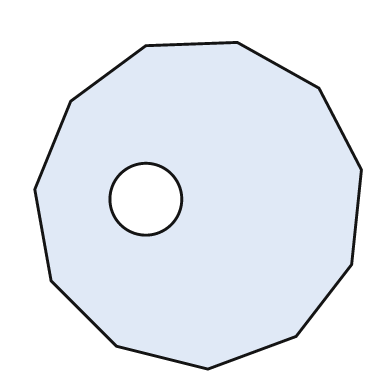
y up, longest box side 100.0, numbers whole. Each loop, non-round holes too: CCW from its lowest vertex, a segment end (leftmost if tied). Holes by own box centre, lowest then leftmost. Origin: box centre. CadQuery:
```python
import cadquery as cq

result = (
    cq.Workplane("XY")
    .moveTo(3.0, -50.0)
    .lineTo(30.0, -40.0)
    .lineTo(47.0, -18.0)
    .lineTo(50.0, 11.0)
    .lineTo(37.0, 36.0)
    .lineTo(12.0, 50.0)
    .lineTo(-16.0, 49.0)
    .lineTo(-39.0, 32.0)
    .lineTo(-50.0, 5.0)
    .lineTo(-45.0, -23.0)
    .lineTo(-25.0, -43.0)
    .close()
    .moveTo(-16.0, 2.0)
    .circle(11.0)
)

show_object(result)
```